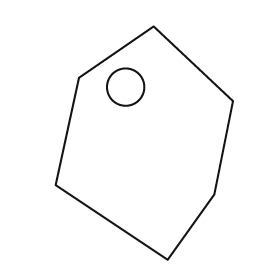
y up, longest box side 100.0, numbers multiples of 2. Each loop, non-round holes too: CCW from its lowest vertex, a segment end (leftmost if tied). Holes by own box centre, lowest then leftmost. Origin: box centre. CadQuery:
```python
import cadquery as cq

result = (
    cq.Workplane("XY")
    .moveTo(10.0, -50.0)
    .lineTo(30.0, -22.0)
    .lineTo(38.0, 18.0)
    .lineTo(4.0, 50.0)
    .lineTo(-28.0, 28.0)
    .lineTo(-38.0, -18.0)
    .close()
    .moveTo(-8.0, 24.0)
    .circle(8.0)
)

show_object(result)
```